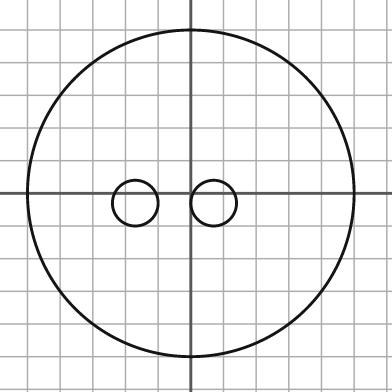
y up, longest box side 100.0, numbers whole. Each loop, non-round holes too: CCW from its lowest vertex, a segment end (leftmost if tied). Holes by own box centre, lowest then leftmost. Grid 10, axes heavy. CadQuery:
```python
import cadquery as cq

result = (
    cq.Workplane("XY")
    .moveTo(0.0, 0.0)
    .circle(50.0)
    .moveTo(-17.0, -3.0)
    .circle(7.0)
    .moveTo(7.0, -3.0)
    .circle(7.0)
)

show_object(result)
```